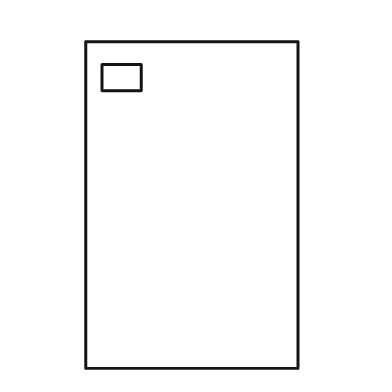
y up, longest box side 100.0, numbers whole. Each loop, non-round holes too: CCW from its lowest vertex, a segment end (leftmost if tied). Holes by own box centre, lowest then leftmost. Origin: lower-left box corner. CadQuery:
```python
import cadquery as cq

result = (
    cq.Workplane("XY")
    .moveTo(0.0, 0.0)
    .lineTo(65.0, 0.0)
    .lineTo(65.0, 100.0)
    .lineTo(0.0, 100.0)
    .close()
    .moveTo(5.0, 85.0)
    .lineTo(17.0, 85.0)
    .lineTo(17.0, 93.0)
    .lineTo(5.0, 93.0)
    .close()
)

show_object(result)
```